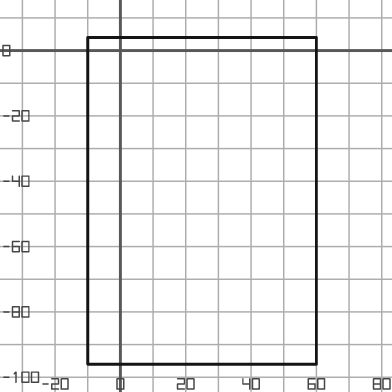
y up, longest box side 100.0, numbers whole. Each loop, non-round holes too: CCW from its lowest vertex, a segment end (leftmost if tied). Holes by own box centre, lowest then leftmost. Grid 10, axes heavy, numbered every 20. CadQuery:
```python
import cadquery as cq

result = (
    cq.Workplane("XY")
    .moveTo(-10.0, -96.0)
    .lineTo(60.0, -96.0)
    .lineTo(60.0, 4.0)
    .lineTo(-10.0, 4.0)
    .close()
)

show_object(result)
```